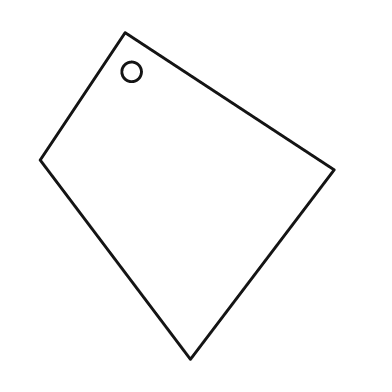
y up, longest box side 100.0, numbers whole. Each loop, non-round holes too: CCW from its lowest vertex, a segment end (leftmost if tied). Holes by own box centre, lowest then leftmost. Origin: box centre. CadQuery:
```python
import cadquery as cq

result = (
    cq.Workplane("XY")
    .moveTo(1.0, -50.0)
    .lineTo(45.0, 8.0)
    .lineTo(-19.0, 50.0)
    .lineTo(-45.0, 11.0)
    .close()
    .moveTo(-17.0, 38.0)
    .circle(3.0)
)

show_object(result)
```